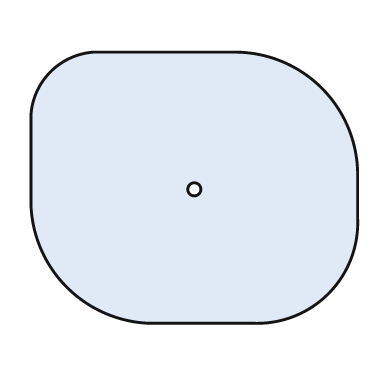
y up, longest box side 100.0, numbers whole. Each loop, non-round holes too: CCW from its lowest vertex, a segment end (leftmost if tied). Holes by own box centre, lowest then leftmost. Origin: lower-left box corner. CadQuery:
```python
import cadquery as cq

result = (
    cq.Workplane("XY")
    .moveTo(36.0, 0.0)
    .lineTo(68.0, 0.0)
    .threePointArc((91.0, 9.0), (100.0, 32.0))
    .lineTo(100.0, 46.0)
    .threePointArc((89.0, 72.0), (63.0, 83.0))
    .lineTo(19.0, 83.0)
    .threePointArc((6.0, 77.0), (0.0, 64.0))
    .lineTo(0.0, 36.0)
    .threePointArc((11.0, 11.0), (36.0, 0.0))
    .close()
    .moveTo(50.0, 41.0)
    .circle(2.0)
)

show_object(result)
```